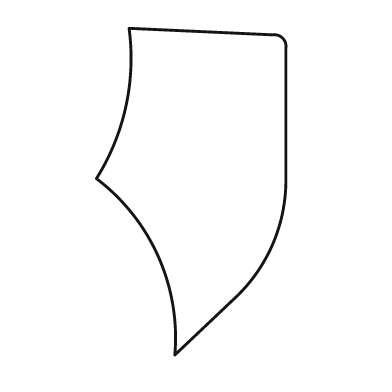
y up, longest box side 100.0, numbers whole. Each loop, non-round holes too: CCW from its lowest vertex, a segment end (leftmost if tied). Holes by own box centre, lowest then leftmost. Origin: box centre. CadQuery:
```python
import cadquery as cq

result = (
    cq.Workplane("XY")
    .moveTo(-5.0, -50.0)
    .lineTo(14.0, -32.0)
    .threePointArc((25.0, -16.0), (29.0, 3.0))
    .lineTo(29.0, 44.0)
    .threePointArc((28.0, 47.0), (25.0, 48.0))
    .lineTo(-19.0, 50.0)
    .threePointArc((-20.0, 26.0), (-29.0, 4.0))
    .threePointArc((-10.0, -20.0), (-5.0, -50.0))
    .close()
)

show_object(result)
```